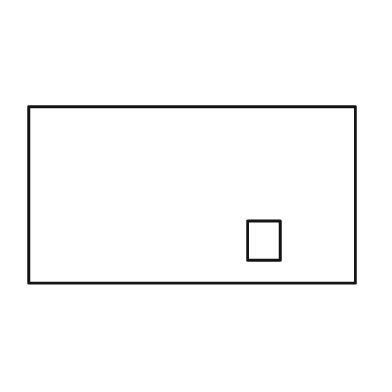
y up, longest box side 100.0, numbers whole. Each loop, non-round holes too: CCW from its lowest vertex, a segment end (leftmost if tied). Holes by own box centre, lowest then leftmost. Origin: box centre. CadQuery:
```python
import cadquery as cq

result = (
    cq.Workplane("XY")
    .moveTo(-50.0, -27.0)
    .lineTo(50.0, -27.0)
    .lineTo(50.0, 27.0)
    .lineTo(-50.0, 27.0)
    .close()
    .moveTo(17.0, -20.0)
    .lineTo(27.0, -20.0)
    .lineTo(27.0, -8.0)
    .lineTo(17.0, -8.0)
    .close()
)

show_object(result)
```